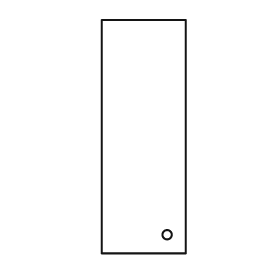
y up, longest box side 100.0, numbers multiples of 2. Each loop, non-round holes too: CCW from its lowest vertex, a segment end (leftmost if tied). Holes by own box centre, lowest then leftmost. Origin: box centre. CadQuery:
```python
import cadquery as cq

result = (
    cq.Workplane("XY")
    .moveTo(-18.0, -50.0)
    .lineTo(18.0, -50.0)
    .lineTo(18.0, 50.0)
    .lineTo(-18.0, 50.0)
    .close()
    .moveTo(10.0, -42.0)
    .circle(2.0)
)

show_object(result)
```